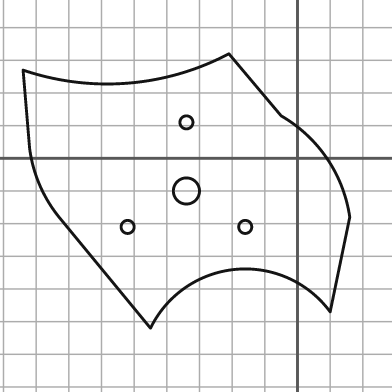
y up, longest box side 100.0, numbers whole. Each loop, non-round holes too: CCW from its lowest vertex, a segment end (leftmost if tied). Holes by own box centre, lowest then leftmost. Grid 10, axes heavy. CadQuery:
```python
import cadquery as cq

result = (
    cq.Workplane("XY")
    .moveTo(-45.0, -52.0)
    .threePointArc((-19.0, -34.0), (10.0, -47.0))
    .lineTo(16.0, -18.0)
    .threePointArc((9.0, 0.0), (-5.0, 13.0))
    .lineTo(-21.0, 32.0)
    .threePointArc((-52.0, 23.0), (-84.0, 27.0))
    .lineTo(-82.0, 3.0)
    .threePointArc((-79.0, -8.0), (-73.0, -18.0))
    .close()
    .moveTo(-52.0, -21.0)
    .circle(2.0)
    .moveTo(-16.0, -21.0)
    .circle(2.0)
    .moveTo(-34.0, -10.0)
    .circle(4.0)
    .moveTo(-34.0, 11.0)
    .circle(2.0)
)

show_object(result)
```